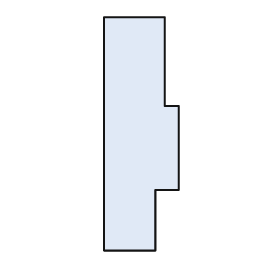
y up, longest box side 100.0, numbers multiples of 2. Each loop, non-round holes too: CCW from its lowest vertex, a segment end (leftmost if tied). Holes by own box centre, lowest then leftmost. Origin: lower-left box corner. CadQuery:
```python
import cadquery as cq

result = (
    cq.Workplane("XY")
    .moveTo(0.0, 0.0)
    .lineTo(22.0, 0.0)
    .lineTo(22.0, 26.0)
    .lineTo(32.0, 26.0)
    .lineTo(32.0, 62.0)
    .lineTo(26.0, 62.0)
    .lineTo(26.0, 100.0)
    .lineTo(0.0, 100.0)
    .close()
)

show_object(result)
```